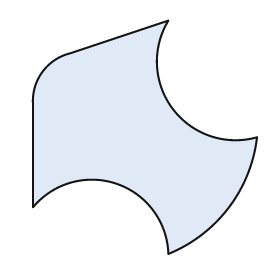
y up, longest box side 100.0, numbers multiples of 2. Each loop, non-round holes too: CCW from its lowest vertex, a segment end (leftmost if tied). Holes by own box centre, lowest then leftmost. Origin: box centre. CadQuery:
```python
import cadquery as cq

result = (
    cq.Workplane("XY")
    .moveTo(10.0, -50.0)
    .threePointArc((36.0, -30.0), (48.0, 0.0))
    .threePointArc((12.0, 12.0), (10.0, 50.0))
    .lineTo(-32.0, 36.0)
    .threePointArc((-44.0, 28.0), (-48.0, 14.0))
    .lineTo(-48.0, -30.0)
    .threePointArc((-12.0, -20.0), (10.0, -50.0))
    .close()
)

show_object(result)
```